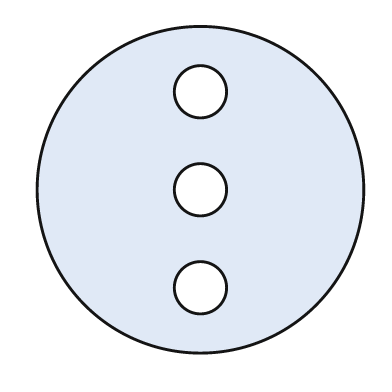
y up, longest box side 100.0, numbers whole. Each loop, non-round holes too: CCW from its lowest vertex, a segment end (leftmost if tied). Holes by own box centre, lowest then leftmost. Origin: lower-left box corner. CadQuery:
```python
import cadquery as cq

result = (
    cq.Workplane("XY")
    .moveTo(50.0, 50.0)
    .circle(50.0)
    .moveTo(50.0, 20.0)
    .circle(8.0)
    .moveTo(50.0, 50.0)
    .circle(8.0)
    .moveTo(50.0, 80.0)
    .circle(8.0)
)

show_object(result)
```